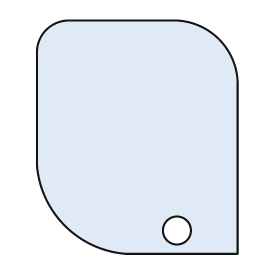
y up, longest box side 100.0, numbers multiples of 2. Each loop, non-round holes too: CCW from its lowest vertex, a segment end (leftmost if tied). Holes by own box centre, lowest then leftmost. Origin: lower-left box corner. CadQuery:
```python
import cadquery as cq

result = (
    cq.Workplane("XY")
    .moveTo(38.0, 0.0)
    .lineTo(86.0, 0.0)
    .lineTo(86.0, 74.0)
    .threePointArc((78.0, 92.0), (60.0, 100.0))
    .lineTo(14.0, 100.0)
    .threePointArc((4.0, 96.0), (0.0, 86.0))
    .lineTo(0.0, 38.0)
    .threePointArc((12.0, 12.0), (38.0, 0.0))
    .close()
    .moveTo(60.0, 10.0)
    .circle(6.0)
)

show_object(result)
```